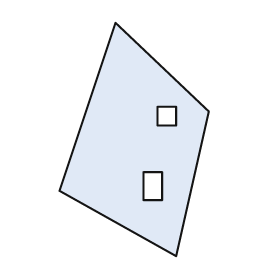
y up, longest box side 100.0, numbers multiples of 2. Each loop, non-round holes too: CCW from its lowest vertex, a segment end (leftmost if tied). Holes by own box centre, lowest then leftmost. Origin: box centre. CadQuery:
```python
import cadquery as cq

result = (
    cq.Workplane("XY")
    .moveTo(18.0, -50.0)
    .lineTo(32.0, 12.0)
    .lineTo(-8.0, 50.0)
    .lineTo(-32.0, -22.0)
    .close()
    .moveTo(4.0, -26.0)
    .lineTo(12.0, -26.0)
    .lineTo(12.0, -14.0)
    .lineTo(4.0, -14.0)
    .close()
    .moveTo(10.0, 6.0)
    .lineTo(18.0, 6.0)
    .lineTo(18.0, 14.0)
    .lineTo(10.0, 14.0)
    .close()
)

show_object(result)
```